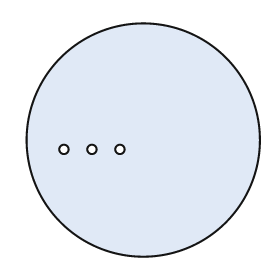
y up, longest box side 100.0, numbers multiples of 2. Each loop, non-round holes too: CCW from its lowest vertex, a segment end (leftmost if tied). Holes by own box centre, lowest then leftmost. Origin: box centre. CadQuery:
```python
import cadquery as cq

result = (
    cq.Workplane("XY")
    .moveTo(0.0, 0.0)
    .circle(50.0)
    .moveTo(-34.0, -4.0)
    .circle(2.0)
    .moveTo(-22.0, -4.0)
    .circle(2.0)
    .moveTo(-10.0, -4.0)
    .circle(2.0)
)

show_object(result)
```